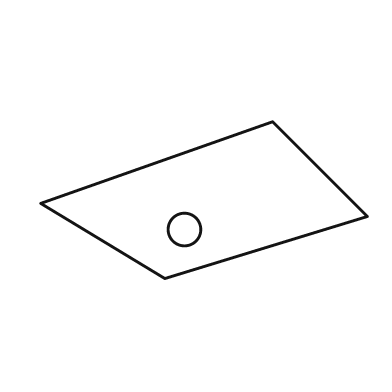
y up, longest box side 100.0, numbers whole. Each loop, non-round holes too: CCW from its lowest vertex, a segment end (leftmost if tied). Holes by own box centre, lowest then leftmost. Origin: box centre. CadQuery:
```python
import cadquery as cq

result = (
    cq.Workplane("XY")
    .moveTo(-12.0, -24.0)
    .lineTo(50.0, -5.0)
    .lineTo(21.0, 24.0)
    .lineTo(-50.0, -1.0)
    .close()
    .moveTo(-6.0, -9.0)
    .circle(5.0)
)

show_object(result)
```